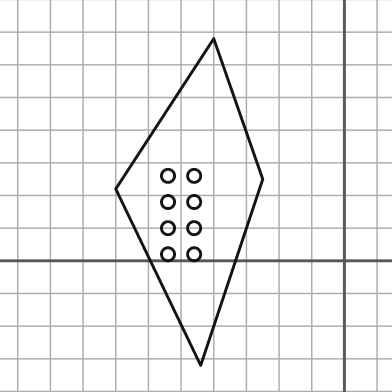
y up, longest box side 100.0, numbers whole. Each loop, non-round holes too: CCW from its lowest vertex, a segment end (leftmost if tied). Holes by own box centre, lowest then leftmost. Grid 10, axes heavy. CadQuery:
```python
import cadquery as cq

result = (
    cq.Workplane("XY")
    .moveTo(-44.0, -32.0)
    .lineTo(-25.0, 25.0)
    .lineTo(-40.0, 68.0)
    .lineTo(-70.0, 22.0)
    .close()
    .moveTo(-54.0, 2.0)
    .circle(2.0)
    .moveTo(-46.0, 2.0)
    .circle(2.0)
    .moveTo(-54.0, 10.0)
    .circle(2.0)
    .moveTo(-46.0, 10.0)
    .circle(2.0)
    .moveTo(-54.0, 18.0)
    .circle(2.0)
    .moveTo(-46.0, 18.0)
    .circle(2.0)
    .moveTo(-54.0, 26.0)
    .circle(2.0)
    .moveTo(-46.0, 26.0)
    .circle(2.0)
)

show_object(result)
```